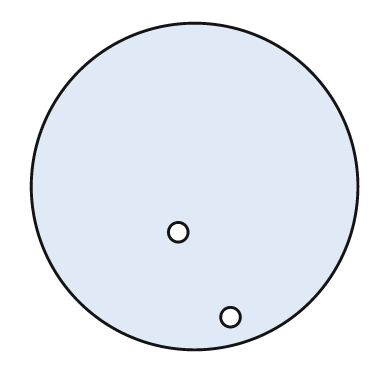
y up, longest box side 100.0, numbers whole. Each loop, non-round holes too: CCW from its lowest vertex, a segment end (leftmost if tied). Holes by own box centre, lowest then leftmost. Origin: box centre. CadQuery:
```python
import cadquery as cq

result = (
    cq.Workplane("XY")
    .moveTo(0.0, 0.0)
    .circle(50.0)
    .moveTo(11.0, -40.0)
    .circle(3.0)
    .moveTo(-5.0, -14.0)
    .circle(3.0)
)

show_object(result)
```